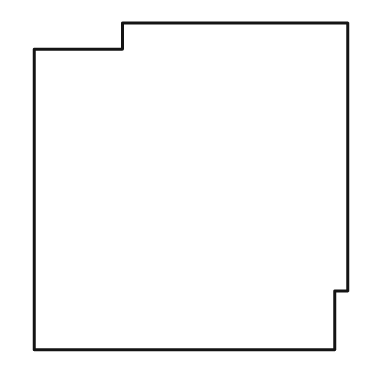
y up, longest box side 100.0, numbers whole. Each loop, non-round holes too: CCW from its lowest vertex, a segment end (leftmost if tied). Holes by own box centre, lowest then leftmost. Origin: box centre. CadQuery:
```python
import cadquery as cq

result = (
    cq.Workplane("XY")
    .moveTo(-48.0, -50.0)
    .lineTo(44.0, -50.0)
    .lineTo(44.0, -32.0)
    .lineTo(48.0, -32.0)
    .lineTo(48.0, 50.0)
    .lineTo(-21.0, 50.0)
    .lineTo(-21.0, 42.0)
    .lineTo(-48.0, 42.0)
    .close()
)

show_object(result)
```